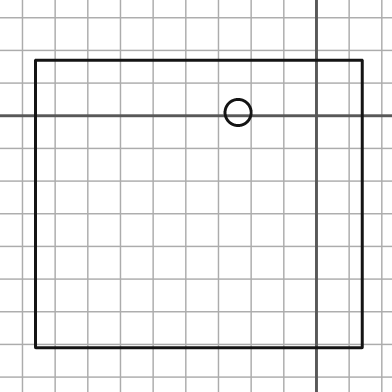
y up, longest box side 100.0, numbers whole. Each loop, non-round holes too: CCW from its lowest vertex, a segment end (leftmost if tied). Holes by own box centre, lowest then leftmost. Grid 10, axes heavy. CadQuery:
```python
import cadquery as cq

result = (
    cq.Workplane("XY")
    .moveTo(-86.0, -71.0)
    .lineTo(14.0, -71.0)
    .lineTo(14.0, 17.0)
    .lineTo(-86.0, 17.0)
    .close()
    .moveTo(-24.0, 1.0)
    .circle(4.0)
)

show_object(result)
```